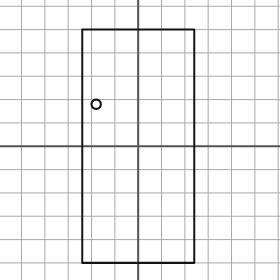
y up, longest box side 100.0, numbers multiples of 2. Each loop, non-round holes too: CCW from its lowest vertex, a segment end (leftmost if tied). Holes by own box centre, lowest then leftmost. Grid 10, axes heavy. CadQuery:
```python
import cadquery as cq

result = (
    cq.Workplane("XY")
    .moveTo(-24.0, -50.0)
    .lineTo(24.0, -50.0)
    .lineTo(24.0, 50.0)
    .lineTo(-24.0, 50.0)
    .close()
    .moveTo(-18.0, 18.0)
    .circle(2.0)
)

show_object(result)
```